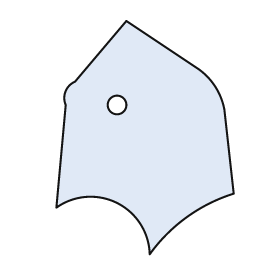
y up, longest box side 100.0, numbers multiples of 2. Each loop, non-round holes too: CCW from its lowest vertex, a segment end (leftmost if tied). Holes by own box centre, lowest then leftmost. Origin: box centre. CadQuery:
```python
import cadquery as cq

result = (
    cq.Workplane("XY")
    .moveTo(2.0, -50.0)
    .threePointArc((18.0, -34.0), (38.0, -24.0))
    .lineTo(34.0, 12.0)
    .threePointArc((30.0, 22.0), (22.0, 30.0))
    .lineTo(-8.0, 50.0)
    .lineTo(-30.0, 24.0)
    .threePointArc((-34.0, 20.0), (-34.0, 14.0))
    .lineTo(-38.0, -30.0)
    .threePointArc((-12.0, -28.0), (2.0, -50.0))
    .close()
    .moveTo(-12.0, 14.0)
    .circle(4.0)
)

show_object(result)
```